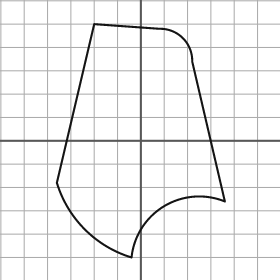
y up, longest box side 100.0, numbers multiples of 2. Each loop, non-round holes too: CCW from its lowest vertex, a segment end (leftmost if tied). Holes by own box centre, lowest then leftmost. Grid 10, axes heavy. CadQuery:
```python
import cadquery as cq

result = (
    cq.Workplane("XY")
    .moveTo(-4.0, -50.0)
    .threePointArc((10.0, -28.0), (36.0, -26.0))
    .lineTo(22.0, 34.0)
    .threePointArc((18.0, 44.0), (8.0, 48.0))
    .lineTo(-20.0, 50.0)
    .lineTo(-36.0, -18.0)
    .threePointArc((-24.0, -38.0), (-4.0, -50.0))
    .close()
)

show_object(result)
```